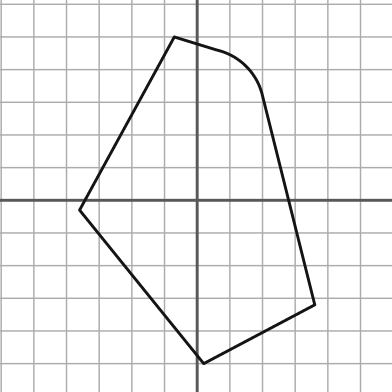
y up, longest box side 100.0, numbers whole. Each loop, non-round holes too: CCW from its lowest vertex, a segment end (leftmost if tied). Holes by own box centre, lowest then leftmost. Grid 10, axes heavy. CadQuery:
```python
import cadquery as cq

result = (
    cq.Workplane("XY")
    .moveTo(2.0, -50.0)
    .lineTo(36.0, -32.0)
    .lineTo(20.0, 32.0)
    .threePointArc((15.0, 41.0), (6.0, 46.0))
    .lineTo(-7.0, 50.0)
    .lineTo(-36.0, -3.0)
    .close()
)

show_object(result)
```